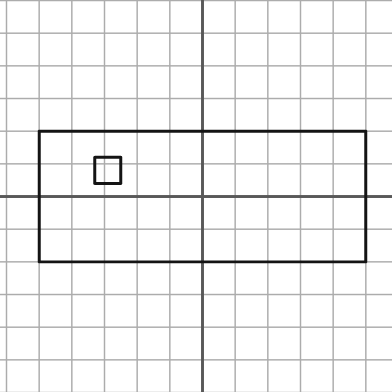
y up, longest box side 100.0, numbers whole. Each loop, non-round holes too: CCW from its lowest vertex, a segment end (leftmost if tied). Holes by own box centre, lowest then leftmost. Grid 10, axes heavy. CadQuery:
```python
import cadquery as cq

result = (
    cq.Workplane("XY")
    .moveTo(-50.0, -20.0)
    .lineTo(50.0, -20.0)
    .lineTo(50.0, 20.0)
    .lineTo(-50.0, 20.0)
    .close()
    .moveTo(-33.0, 4.0)
    .lineTo(-25.0, 4.0)
    .lineTo(-25.0, 12.0)
    .lineTo(-33.0, 12.0)
    .close()
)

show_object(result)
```